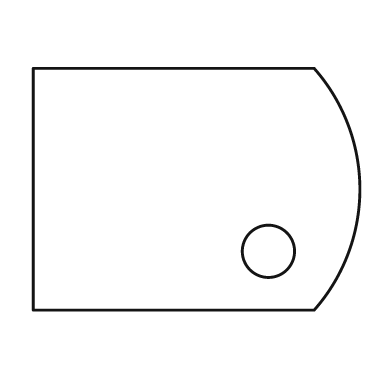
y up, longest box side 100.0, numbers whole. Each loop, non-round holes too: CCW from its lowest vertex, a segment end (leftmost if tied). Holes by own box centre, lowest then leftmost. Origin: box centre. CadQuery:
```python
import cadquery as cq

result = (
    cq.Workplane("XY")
    .moveTo(-50.0, -37.0)
    .lineTo(36.0, -37.0)
    .threePointArc((50.0, 0.0), (36.0, 37.0))
    .lineTo(-50.0, 37.0)
    .close()
    .moveTo(22.0, -19.0)
    .circle(8.0)
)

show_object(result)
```